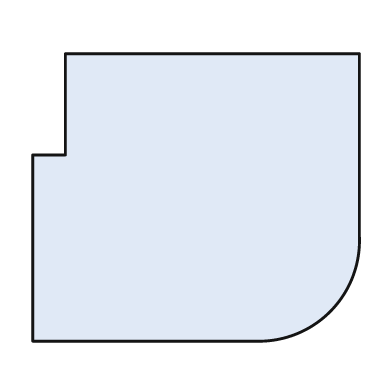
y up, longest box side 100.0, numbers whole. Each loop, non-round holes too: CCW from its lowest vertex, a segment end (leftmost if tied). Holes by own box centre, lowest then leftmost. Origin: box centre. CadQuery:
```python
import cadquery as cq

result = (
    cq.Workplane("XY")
    .moveTo(-50.0, -44.0)
    .lineTo(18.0, -44.0)
    .threePointArc((41.0, -35.0), (50.0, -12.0))
    .lineTo(50.0, 44.0)
    .lineTo(-40.0, 44.0)
    .lineTo(-40.0, 13.0)
    .lineTo(-50.0, 13.0)
    .close()
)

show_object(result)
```